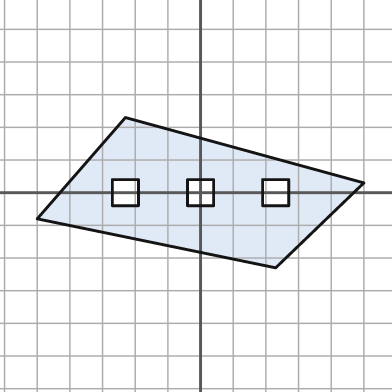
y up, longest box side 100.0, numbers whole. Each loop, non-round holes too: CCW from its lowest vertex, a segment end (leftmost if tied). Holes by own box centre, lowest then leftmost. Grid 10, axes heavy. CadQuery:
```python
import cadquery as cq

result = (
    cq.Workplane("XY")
    .moveTo(23.0, -23.0)
    .lineTo(50.0, 3.0)
    .lineTo(-23.0, 23.0)
    .lineTo(-50.0, -8.0)
    .close()
    .moveTo(-27.0, -4.0)
    .lineTo(-19.0, -4.0)
    .lineTo(-19.0, 4.0)
    .lineTo(-27.0, 4.0)
    .close()
    .moveTo(-4.0, -4.0)
    .lineTo(4.0, -4.0)
    .lineTo(4.0, 4.0)
    .lineTo(-4.0, 4.0)
    .close()
    .moveTo(19.0, -4.0)
    .lineTo(27.0, -4.0)
    .lineTo(27.0, 4.0)
    .lineTo(19.0, 4.0)
    .close()
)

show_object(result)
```